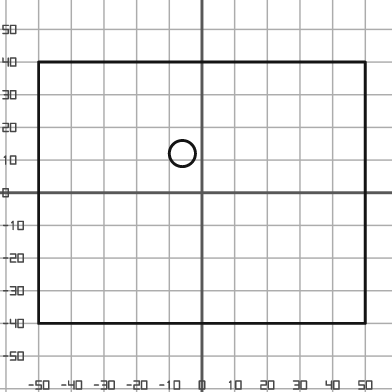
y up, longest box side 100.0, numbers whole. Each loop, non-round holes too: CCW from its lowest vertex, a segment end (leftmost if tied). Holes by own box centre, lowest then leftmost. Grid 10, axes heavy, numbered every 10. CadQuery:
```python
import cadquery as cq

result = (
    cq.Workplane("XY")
    .moveTo(-50.0, -40.0)
    .lineTo(50.0, -40.0)
    .lineTo(50.0, 40.0)
    .lineTo(-50.0, 40.0)
    .close()
    .moveTo(-6.0, 12.0)
    .circle(4.0)
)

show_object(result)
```